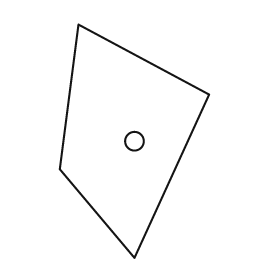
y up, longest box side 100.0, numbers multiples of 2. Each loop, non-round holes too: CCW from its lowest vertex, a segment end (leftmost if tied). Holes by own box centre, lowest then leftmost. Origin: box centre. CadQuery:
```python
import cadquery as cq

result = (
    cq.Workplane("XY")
    .moveTo(0.0, -50.0)
    .lineTo(32.0, 20.0)
    .lineTo(-24.0, 50.0)
    .lineTo(-32.0, -12.0)
    .close()
    .moveTo(0.0, 0.0)
    .circle(4.0)
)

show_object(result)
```